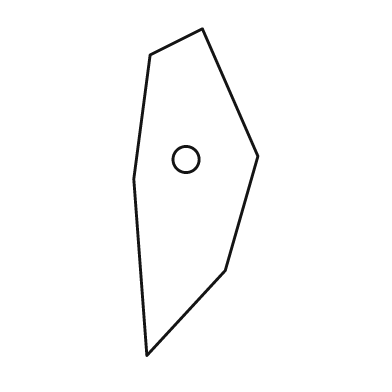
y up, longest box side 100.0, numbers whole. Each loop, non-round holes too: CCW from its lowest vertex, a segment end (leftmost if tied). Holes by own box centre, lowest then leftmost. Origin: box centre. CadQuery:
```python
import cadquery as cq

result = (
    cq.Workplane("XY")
    .moveTo(-15.0, -50.0)
    .lineTo(9.0, -24.0)
    .lineTo(19.0, 11.0)
    .lineTo(2.0, 50.0)
    .lineTo(-14.0, 42.0)
    .lineTo(-19.0, 4.0)
    .close()
    .moveTo(-3.0, 10.0)
    .circle(4.0)
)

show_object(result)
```